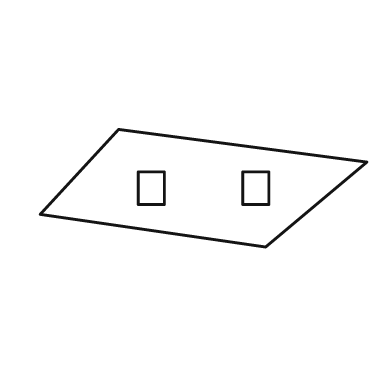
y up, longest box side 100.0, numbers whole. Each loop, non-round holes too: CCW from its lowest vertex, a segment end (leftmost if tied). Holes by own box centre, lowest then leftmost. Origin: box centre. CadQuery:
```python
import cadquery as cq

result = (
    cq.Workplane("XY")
    .moveTo(19.0, -18.0)
    .lineTo(50.0, 8.0)
    .lineTo(-26.0, 18.0)
    .lineTo(-50.0, -8.0)
    .close()
    .moveTo(-20.0, -5.0)
    .lineTo(-12.0, -5.0)
    .lineTo(-12.0, 5.0)
    .lineTo(-20.0, 5.0)
    .close()
    .moveTo(12.0, -5.0)
    .lineTo(20.0, -5.0)
    .lineTo(20.0, 5.0)
    .lineTo(12.0, 5.0)
    .close()
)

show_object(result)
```